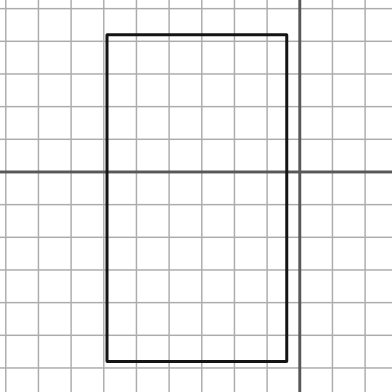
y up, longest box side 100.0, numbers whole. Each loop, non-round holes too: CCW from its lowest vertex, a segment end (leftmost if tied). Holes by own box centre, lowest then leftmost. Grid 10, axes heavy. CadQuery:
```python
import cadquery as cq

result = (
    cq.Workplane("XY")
    .moveTo(-59.0, -58.0)
    .lineTo(-4.0, -58.0)
    .lineTo(-4.0, 42.0)
    .lineTo(-59.0, 42.0)
    .close()
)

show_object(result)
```